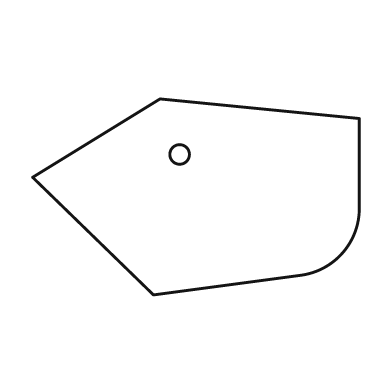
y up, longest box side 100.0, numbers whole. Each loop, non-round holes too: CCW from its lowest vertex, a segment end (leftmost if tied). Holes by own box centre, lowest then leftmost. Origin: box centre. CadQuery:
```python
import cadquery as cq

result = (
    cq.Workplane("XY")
    .moveTo(-13.0, -30.0)
    .lineTo(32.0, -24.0)
    .threePointArc((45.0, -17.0), (50.0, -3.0))
    .lineTo(50.0, 24.0)
    .lineTo(-11.0, 30.0)
    .lineTo(-50.0, 6.0)
    .close()
    .moveTo(-5.0, 13.0)
    .circle(3.0)
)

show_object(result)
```